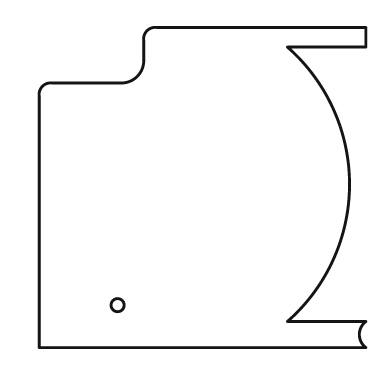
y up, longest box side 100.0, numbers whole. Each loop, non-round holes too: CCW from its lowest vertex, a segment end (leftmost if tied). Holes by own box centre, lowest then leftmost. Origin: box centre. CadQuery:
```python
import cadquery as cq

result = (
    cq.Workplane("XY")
    .moveTo(-50.0, -49.0)
    .lineTo(50.0, -49.0)
    .threePointArc((48.0, -45.0), (50.0, -41.0))
    .lineTo(26.0, -41.0)
    .threePointArc((45.0, 1.0), (26.0, 43.0))
    .lineTo(50.0, 43.0)
    .lineTo(50.0, 49.0)
    .lineTo(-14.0, 49.0)
    .threePointArc((-17.0, 48.0), (-18.0, 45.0))
    .lineTo(-18.0, 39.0)
    .threePointArc((-20.0, 34.0), (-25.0, 32.0))
    .lineTo(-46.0, 32.0)
    .threePointArc((-49.0, 31.0), (-50.0, 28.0))
    .close()
    .moveTo(-26.0, -36.0)
    .circle(2.0)
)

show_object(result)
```